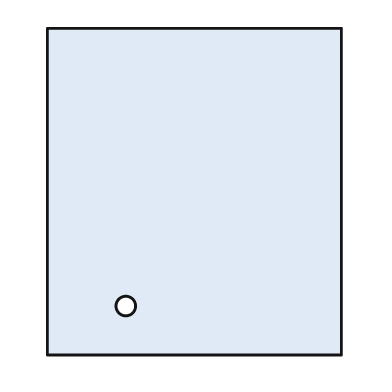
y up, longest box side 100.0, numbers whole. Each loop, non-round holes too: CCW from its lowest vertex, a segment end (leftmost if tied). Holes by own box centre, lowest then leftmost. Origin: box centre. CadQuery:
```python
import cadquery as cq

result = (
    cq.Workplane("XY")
    .moveTo(-45.0, -50.0)
    .lineTo(45.0, -50.0)
    .lineTo(45.0, 50.0)
    .lineTo(-45.0, 50.0)
    .close()
    .moveTo(-21.0, -35.0)
    .circle(3.0)
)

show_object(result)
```